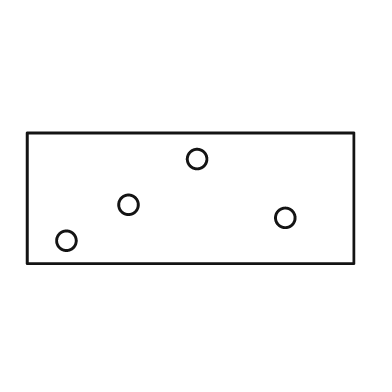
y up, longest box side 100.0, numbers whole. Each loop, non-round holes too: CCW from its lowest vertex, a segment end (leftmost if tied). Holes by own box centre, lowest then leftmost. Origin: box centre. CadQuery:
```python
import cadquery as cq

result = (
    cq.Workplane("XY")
    .moveTo(-50.0, -20.0)
    .lineTo(50.0, -20.0)
    .lineTo(50.0, 20.0)
    .lineTo(-50.0, 20.0)
    .close()
    .moveTo(-38.0, -13.0)
    .circle(3.0)
    .moveTo(29.0, -6.0)
    .circle(3.0)
    .moveTo(-19.0, -2.0)
    .circle(3.0)
    .moveTo(2.0, 12.0)
    .circle(3.0)
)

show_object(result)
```